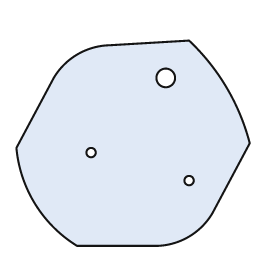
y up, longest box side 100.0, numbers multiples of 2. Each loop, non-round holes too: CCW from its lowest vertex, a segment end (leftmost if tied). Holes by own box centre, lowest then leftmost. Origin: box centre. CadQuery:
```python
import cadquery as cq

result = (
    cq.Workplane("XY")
    .moveTo(-24.0, -44.0)
    .lineTo(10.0, -44.0)
    .threePointArc((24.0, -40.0), (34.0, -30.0))
    .lineTo(50.0, 0.0)
    .threePointArc((40.0, 24.0), (24.0, 44.0))
    .lineTo(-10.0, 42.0)
    .threePointArc((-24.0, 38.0), (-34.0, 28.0))
    .lineTo(-50.0, -2.0)
    .threePointArc((-42.0, -26.0), (-24.0, -44.0))
    .close()
    .moveTo(24.0, -16.0)
    .circle(2.0)
    .moveTo(-18.0, -4.0)
    .circle(2.0)
    .moveTo(14.0, 28.0)
    .circle(4.0)
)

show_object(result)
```